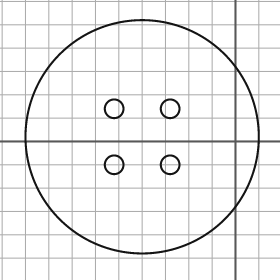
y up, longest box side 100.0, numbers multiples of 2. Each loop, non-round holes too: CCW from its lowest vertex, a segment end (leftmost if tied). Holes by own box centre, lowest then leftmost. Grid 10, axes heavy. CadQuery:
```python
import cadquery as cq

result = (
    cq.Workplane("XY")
    .moveTo(-40.0, 2.0)
    .circle(50.0)
    .moveTo(-52.0, -10.0)
    .circle(4.0)
    .moveTo(-28.0, -10.0)
    .circle(4.0)
    .moveTo(-52.0, 14.0)
    .circle(4.0)
    .moveTo(-28.0, 14.0)
    .circle(4.0)
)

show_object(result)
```